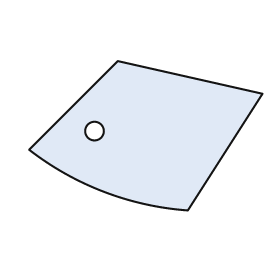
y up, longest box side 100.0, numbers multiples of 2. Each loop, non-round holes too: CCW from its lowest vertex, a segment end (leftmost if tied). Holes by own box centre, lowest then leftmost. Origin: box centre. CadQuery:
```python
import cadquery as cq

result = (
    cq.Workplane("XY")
    .moveTo(18.0, -32.0)
    .lineTo(50.0, 18.0)
    .lineTo(-12.0, 32.0)
    .lineTo(-50.0, -6.0)
    .threePointArc((-18.0, -24.0), (18.0, -32.0))
    .close()
    .moveTo(-22.0, 2.0)
    .circle(4.0)
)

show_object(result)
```